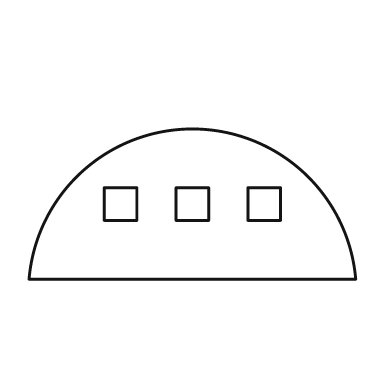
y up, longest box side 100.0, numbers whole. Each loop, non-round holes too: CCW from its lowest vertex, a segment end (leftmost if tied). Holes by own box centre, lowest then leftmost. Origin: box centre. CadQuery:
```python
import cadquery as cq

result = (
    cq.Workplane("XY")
    .moveTo(-50.0, -23.0)
    .lineTo(50.0, -23.0)
    .threePointArc((0.0, 23.0), (-50.0, -23.0))
    .close()
    .moveTo(-27.0, -5.0)
    .lineTo(-17.0, -5.0)
    .lineTo(-17.0, 5.0)
    .lineTo(-27.0, 5.0)
    .close()
    .moveTo(-5.0, -5.0)
    .lineTo(5.0, -5.0)
    .lineTo(5.0, 5.0)
    .lineTo(-5.0, 5.0)
    .close()
    .moveTo(17.0, -5.0)
    .lineTo(27.0, -5.0)
    .lineTo(27.0, 5.0)
    .lineTo(17.0, 5.0)
    .close()
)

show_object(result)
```